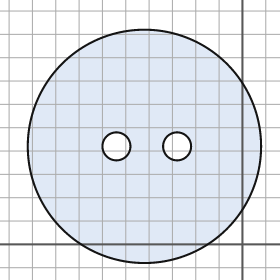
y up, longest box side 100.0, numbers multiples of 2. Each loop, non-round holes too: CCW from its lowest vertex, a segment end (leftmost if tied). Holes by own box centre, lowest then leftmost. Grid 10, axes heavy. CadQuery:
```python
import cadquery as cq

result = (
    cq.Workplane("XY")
    .moveTo(-42.0, 42.0)
    .circle(50.0)
    .moveTo(-54.0, 42.0)
    .circle(6.0)
    .moveTo(-28.0, 42.0)
    .circle(6.0)
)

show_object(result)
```